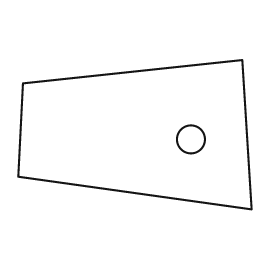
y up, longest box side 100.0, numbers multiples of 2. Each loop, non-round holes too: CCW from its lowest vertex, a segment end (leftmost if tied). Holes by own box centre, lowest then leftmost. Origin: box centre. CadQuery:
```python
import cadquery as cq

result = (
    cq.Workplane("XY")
    .moveTo(50.0, -32.0)
    .lineTo(46.0, 32.0)
    .lineTo(-48.0, 22.0)
    .lineTo(-50.0, -18.0)
    .close()
    .moveTo(24.0, -2.0)
    .circle(6.0)
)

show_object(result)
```